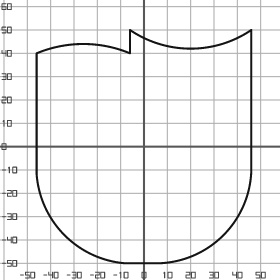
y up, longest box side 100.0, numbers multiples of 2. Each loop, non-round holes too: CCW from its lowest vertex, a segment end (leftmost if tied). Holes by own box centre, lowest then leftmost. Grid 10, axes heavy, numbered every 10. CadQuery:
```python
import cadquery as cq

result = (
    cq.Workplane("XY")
    .moveTo(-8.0, -50.0)
    .lineTo(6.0, -50.0)
    .threePointArc((34.0, -38.0), (46.0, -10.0))
    .lineTo(46.0, 50.0)
    .threePointArc((20.0, 42.0), (-6.0, 50.0))
    .lineTo(-6.0, 40.0)
    .threePointArc((-26.0, 44.0), (-46.0, 40.0))
    .lineTo(-46.0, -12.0)
    .threePointArc((-34.0, -38.0), (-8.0, -50.0))
    .close()
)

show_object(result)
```